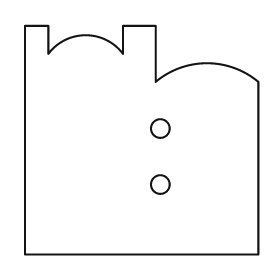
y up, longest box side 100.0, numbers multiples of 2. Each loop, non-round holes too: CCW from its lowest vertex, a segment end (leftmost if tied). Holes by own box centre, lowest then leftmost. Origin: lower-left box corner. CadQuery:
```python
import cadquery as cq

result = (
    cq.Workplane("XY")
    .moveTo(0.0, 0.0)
    .lineTo(100.0, 0.0)
    .lineTo(100.0, 74.0)
    .threePointArc((78.0, 82.0), (56.0, 74.0))
    .lineTo(56.0, 98.0)
    .lineTo(42.0, 98.0)
    .lineTo(42.0, 86.0)
    .threePointArc((26.0, 94.0), (10.0, 86.0))
    .lineTo(10.0, 98.0)
    .lineTo(0.0, 98.0)
    .close()
    .moveTo(58.0, 30.0)
    .circle(4.0)
    .moveTo(58.0, 54.0)
    .circle(4.0)
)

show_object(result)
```